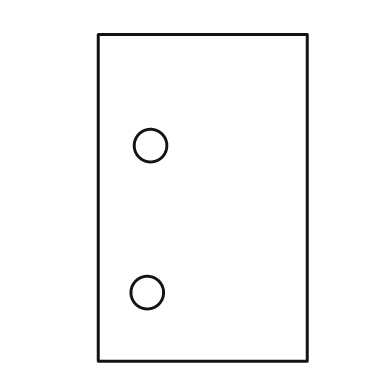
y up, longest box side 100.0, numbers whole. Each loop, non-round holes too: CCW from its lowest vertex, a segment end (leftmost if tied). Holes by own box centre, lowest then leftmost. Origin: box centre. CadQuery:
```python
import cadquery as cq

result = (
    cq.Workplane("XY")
    .moveTo(-32.0, -50.0)
    .lineTo(32.0, -50.0)
    .lineTo(32.0, 50.0)
    .lineTo(-32.0, 50.0)
    .close()
    .moveTo(-17.0, -29.0)
    .circle(5.0)
    .moveTo(-16.0, 16.0)
    .circle(5.0)
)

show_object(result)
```